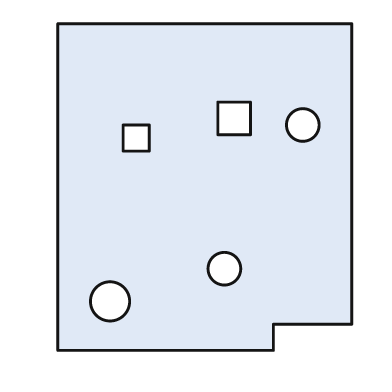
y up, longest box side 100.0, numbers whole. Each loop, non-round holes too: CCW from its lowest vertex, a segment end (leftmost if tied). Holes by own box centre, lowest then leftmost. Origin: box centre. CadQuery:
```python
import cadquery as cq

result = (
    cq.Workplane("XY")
    .moveTo(-45.0, -50.0)
    .lineTo(21.0, -50.0)
    .lineTo(21.0, -42.0)
    .lineTo(45.0, -42.0)
    .lineTo(45.0, 50.0)
    .lineTo(-45.0, 50.0)
    .close()
    .moveTo(-29.0, -35.0)
    .circle(6.0)
    .moveTo(6.0, -25.0)
    .circle(5.0)
    .moveTo(-25.0, 11.0)
    .lineTo(-17.0, 11.0)
    .lineTo(-17.0, 19.0)
    .lineTo(-25.0, 19.0)
    .close()
    .moveTo(30.0, 19.0)
    .circle(5.0)
    .moveTo(4.0, 16.0)
    .lineTo(14.0, 16.0)
    .lineTo(14.0, 26.0)
    .lineTo(4.0, 26.0)
    .close()
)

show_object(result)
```